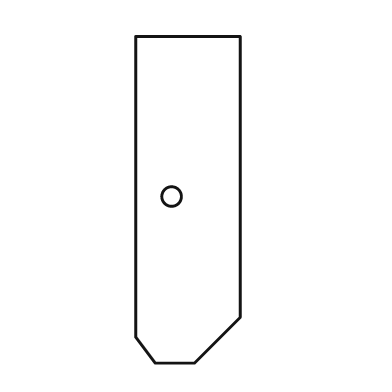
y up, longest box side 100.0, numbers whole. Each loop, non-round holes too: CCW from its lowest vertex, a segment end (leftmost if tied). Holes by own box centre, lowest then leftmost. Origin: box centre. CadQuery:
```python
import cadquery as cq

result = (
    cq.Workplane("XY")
    .moveTo(-10.0, -50.0)
    .lineTo(2.0, -50.0)
    .lineTo(16.0, -36.0)
    .lineTo(16.0, 50.0)
    .lineTo(-16.0, 50.0)
    .lineTo(-16.0, -42.0)
    .close()
    .moveTo(-5.0, 1.0)
    .circle(3.0)
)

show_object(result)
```